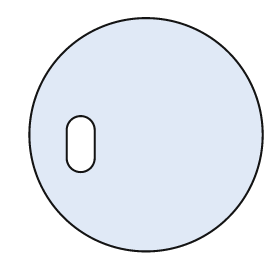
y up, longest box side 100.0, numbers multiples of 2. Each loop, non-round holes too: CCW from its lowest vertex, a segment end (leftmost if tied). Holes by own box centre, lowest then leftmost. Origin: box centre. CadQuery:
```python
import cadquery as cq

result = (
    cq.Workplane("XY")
    .moveTo(0.0, 0.0)
    .circle(50.0)
    .moveTo(-34.0, -10.0)
    .threePointArc((-28.0, -16.0), (-22.0, -10.0))
    .lineTo(-22.0, 2.0)
    .threePointArc((-28.0, 8.0), (-34.0, 2.0))
    .close()
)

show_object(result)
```